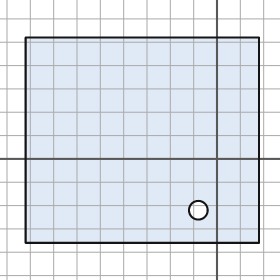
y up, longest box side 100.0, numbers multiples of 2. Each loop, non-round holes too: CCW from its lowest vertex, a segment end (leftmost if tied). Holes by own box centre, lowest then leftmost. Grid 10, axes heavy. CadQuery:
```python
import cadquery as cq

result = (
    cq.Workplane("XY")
    .moveTo(-82.0, -36.0)
    .lineTo(18.0, -36.0)
    .lineTo(18.0, 52.0)
    .lineTo(-82.0, 52.0)
    .close()
    .moveTo(-8.0, -22.0)
    .circle(4.0)
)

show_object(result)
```